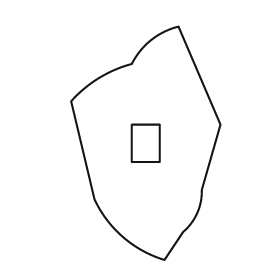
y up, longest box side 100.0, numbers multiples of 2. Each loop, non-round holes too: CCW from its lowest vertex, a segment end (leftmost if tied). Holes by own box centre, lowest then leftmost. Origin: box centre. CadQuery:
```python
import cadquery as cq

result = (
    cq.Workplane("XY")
    .moveTo(8.0, -50.0)
    .lineTo(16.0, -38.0)
    .threePointArc((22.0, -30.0), (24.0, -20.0))
    .lineTo(32.0, 8.0)
    .lineTo(14.0, 50.0)
    .threePointArc((2.0, 44.0), (-6.0, 34.0))
    .threePointArc((-20.0, 28.0), (-32.0, 18.0))
    .lineTo(-22.0, -24.0)
    .threePointArc((-10.0, -40.0), (8.0, -50.0))
    .close()
    .moveTo(-6.0, -8.0)
    .lineTo(6.0, -8.0)
    .lineTo(6.0, 8.0)
    .lineTo(-6.0, 8.0)
    .close()
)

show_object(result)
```